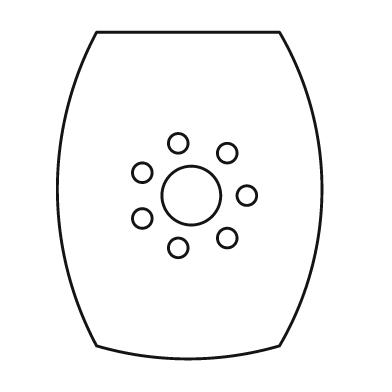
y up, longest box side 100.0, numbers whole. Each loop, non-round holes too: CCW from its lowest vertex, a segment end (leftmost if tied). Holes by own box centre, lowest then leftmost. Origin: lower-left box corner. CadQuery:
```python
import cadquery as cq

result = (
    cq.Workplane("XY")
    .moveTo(12.0, 4.0)
    .threePointArc((40.0, 0.0), (68.0, 4.0))
    .threePointArc((81.0, 52.0), (68.0, 100.0))
    .lineTo(12.0, 100.0)
    .threePointArc((0.0, 52.0), (12.0, 4.0))
    .close()
    .moveTo(37.0, 34.0)
    .circle(3.0)
    .moveTo(52.0, 37.0)
    .circle(3.0)
    .moveTo(26.0, 43.0)
    .circle(3.0)
    .moveTo(41.0, 50.0)
    .circle(9.0)
    .moveTo(58.0, 50.0)
    .circle(3.0)
    .moveTo(26.0, 57.0)
    .circle(3.0)
    .moveTo(52.0, 63.0)
    .circle(3.0)
    .moveTo(37.0, 66.0)
    .circle(3.0)
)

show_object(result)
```